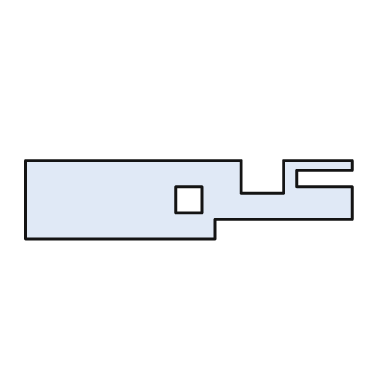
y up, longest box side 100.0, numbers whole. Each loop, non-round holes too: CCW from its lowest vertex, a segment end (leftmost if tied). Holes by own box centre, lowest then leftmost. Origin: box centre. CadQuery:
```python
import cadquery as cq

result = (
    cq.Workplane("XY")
    .moveTo(-50.0, -12.0)
    .lineTo(8.0, -12.0)
    .lineTo(8.0, -6.0)
    .lineTo(50.0, -6.0)
    .lineTo(50.0, 4.0)
    .lineTo(33.0, 4.0)
    .lineTo(33.0, 9.0)
    .lineTo(50.0, 9.0)
    .lineTo(50.0, 12.0)
    .lineTo(29.0, 12.0)
    .lineTo(29.0, 2.0)
    .lineTo(16.0, 2.0)
    .lineTo(16.0, 12.0)
    .lineTo(-50.0, 12.0)
    .close()
    .moveTo(-4.0, -4.0)
    .lineTo(4.0, -4.0)
    .lineTo(4.0, 4.0)
    .lineTo(-4.0, 4.0)
    .close()
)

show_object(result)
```